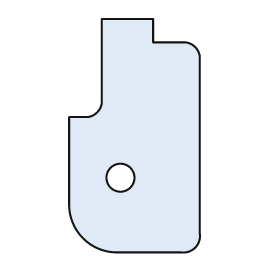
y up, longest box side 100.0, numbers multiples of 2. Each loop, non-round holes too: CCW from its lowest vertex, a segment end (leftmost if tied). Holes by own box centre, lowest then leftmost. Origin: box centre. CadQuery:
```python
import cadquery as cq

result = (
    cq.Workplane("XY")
    .moveTo(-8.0, -50.0)
    .lineTo(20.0, -50.0)
    .threePointArc((26.0, -48.0), (28.0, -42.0))
    .lineTo(28.0, 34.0)
    .threePointArc((26.0, 38.0), (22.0, 40.0))
    .lineTo(8.0, 40.0)
    .lineTo(8.0, 50.0)
    .lineTo(-14.0, 50.0)
    .lineTo(-14.0, 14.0)
    .threePointArc((-16.0, 10.0), (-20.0, 8.0))
    .lineTo(-28.0, 8.0)
    .lineTo(-28.0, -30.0)
    .threePointArc((-22.0, -44.0), (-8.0, -50.0))
    .close()
    .moveTo(-6.0, -18.0)
    .circle(6.0)
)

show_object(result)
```